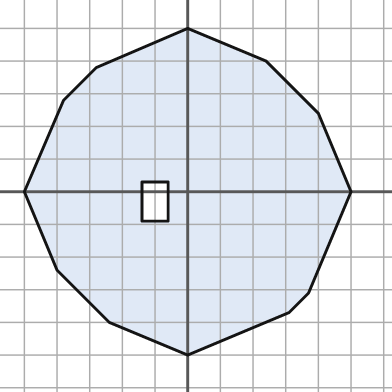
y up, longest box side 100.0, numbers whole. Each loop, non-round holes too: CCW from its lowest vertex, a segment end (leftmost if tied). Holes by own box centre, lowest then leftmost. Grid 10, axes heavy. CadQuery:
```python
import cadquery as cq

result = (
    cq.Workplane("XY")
    .moveTo(0.0, -50.0)
    .lineTo(31.0, -37.0)
    .lineTo(37.0, -31.0)
    .lineTo(50.0, 0.0)
    .lineTo(40.0, 24.0)
    .lineTo(24.0, 40.0)
    .lineTo(0.0, 50.0)
    .lineTo(-28.0, 38.0)
    .lineTo(-38.0, 28.0)
    .lineTo(-50.0, 0.0)
    .lineTo(-40.0, -24.0)
    .lineTo(-24.0, -40.0)
    .close()
    .moveTo(-14.0, -9.0)
    .lineTo(-6.0, -9.0)
    .lineTo(-6.0, 3.0)
    .lineTo(-14.0, 3.0)
    .close()
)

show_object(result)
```